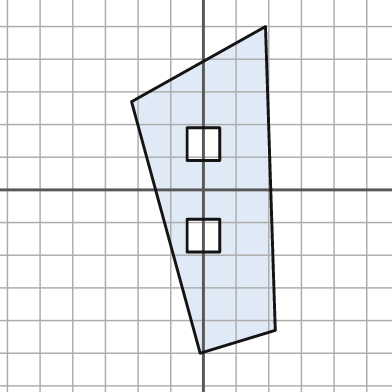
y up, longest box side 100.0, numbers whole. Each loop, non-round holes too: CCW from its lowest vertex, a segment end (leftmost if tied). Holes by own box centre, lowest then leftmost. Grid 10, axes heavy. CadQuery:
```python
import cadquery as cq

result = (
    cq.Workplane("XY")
    .moveTo(-1.0, -50.0)
    .lineTo(22.0, -43.0)
    .lineTo(19.0, 50.0)
    .lineTo(-22.0, 27.0)
    .close()
    .moveTo(-5.0, -19.0)
    .lineTo(5.0, -19.0)
    .lineTo(5.0, -9.0)
    .lineTo(-5.0, -9.0)
    .close()
    .moveTo(-5.0, 9.0)
    .lineTo(5.0, 9.0)
    .lineTo(5.0, 19.0)
    .lineTo(-5.0, 19.0)
    .close()
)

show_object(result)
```